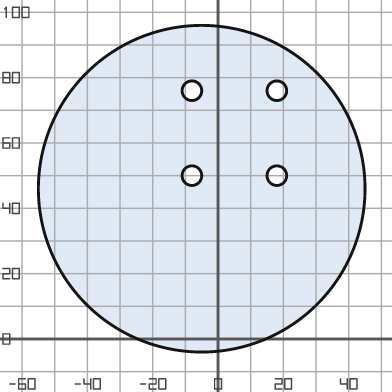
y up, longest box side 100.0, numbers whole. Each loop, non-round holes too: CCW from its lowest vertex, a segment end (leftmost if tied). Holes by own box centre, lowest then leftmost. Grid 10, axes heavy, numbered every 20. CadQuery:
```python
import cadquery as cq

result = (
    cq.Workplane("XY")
    .moveTo(-5.0, 46.0)
    .circle(50.0)
    .moveTo(-8.0, 50.0)
    .circle(3.0)
    .moveTo(18.0, 50.0)
    .circle(3.0)
    .moveTo(-8.0, 76.0)
    .circle(3.0)
    .moveTo(18.0, 76.0)
    .circle(3.0)
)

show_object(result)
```